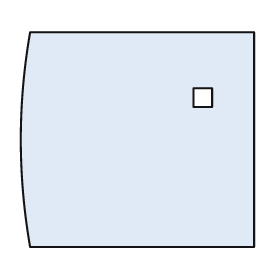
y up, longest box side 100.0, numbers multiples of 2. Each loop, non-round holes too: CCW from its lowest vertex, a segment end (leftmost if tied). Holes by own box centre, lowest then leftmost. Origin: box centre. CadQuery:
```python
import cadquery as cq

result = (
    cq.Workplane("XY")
    .moveTo(-46.0, -46.0)
    .lineTo(50.0, -46.0)
    .lineTo(50.0, 46.0)
    .lineTo(-46.0, 46.0)
    .threePointArc((-50.0, 0.0), (-46.0, -46.0))
    .close()
    .moveTo(24.0, 14.0)
    .lineTo(32.0, 14.0)
    .lineTo(32.0, 22.0)
    .lineTo(24.0, 22.0)
    .close()
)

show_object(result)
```